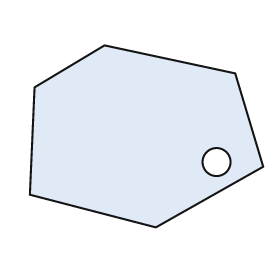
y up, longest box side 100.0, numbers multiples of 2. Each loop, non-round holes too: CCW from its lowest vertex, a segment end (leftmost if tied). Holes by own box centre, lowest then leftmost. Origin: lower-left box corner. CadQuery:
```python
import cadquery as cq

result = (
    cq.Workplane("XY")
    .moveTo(54.0, 0.0)
    .lineTo(100.0, 26.0)
    .lineTo(88.0, 66.0)
    .lineTo(32.0, 78.0)
    .lineTo(2.0, 60.0)
    .lineTo(0.0, 14.0)
    .close()
    .moveTo(80.0, 28.0)
    .circle(6.0)
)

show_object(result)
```